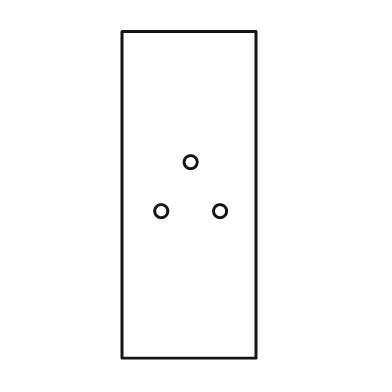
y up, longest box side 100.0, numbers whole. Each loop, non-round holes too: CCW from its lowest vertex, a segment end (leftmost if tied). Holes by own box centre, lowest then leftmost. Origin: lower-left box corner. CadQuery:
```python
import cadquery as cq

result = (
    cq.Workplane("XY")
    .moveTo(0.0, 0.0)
    .lineTo(41.0, 0.0)
    .lineTo(41.0, 100.0)
    .lineTo(0.0, 100.0)
    .close()
    .moveTo(12.0, 45.0)
    .circle(2.0)
    .moveTo(30.0, 45.0)
    .circle(2.0)
    .moveTo(21.0, 60.0)
    .circle(2.0)
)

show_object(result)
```